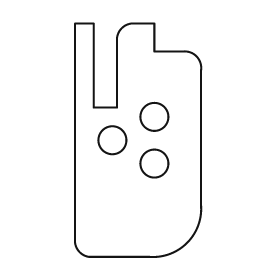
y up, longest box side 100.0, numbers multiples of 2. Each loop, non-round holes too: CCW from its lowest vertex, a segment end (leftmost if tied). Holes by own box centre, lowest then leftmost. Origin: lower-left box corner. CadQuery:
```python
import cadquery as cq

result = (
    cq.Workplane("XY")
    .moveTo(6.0, 0.0)
    .lineTo(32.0, 0.0)
    .threePointArc((48.0, 6.0), (54.0, 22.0))
    .lineTo(54.0, 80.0)
    .threePointArc((52.0, 86.0), (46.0, 88.0))
    .lineTo(34.0, 88.0)
    .lineTo(34.0, 100.0)
    .lineTo(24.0, 100.0)
    .threePointArc((20.0, 98.0), (18.0, 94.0))
    .lineTo(18.0, 64.0)
    .lineTo(8.0, 64.0)
    .lineTo(8.0, 100.0)
    .lineTo(0.0, 100.0)
    .lineTo(0.0, 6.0)
    .threePointArc((2.0, 2.0), (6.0, 0.0))
    .close()
    .moveTo(34.0, 40.0)
    .circle(6.0)
    .moveTo(16.0, 50.0)
    .circle(6.0)
    .moveTo(34.0, 60.0)
    .circle(6.0)
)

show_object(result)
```